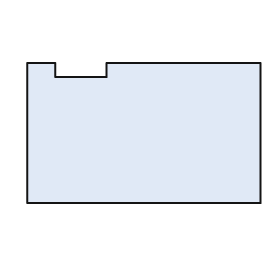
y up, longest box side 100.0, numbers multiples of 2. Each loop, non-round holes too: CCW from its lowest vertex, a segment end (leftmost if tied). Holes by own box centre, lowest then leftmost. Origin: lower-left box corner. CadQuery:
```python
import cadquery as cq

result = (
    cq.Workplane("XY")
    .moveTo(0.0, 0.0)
    .lineTo(100.0, 0.0)
    .lineTo(100.0, 60.0)
    .lineTo(34.0, 60.0)
    .lineTo(34.0, 54.0)
    .lineTo(12.0, 54.0)
    .lineTo(12.0, 60.0)
    .lineTo(0.0, 60.0)
    .close()
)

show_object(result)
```